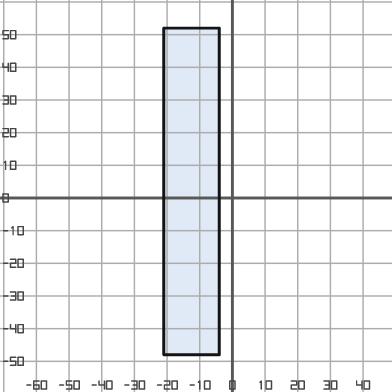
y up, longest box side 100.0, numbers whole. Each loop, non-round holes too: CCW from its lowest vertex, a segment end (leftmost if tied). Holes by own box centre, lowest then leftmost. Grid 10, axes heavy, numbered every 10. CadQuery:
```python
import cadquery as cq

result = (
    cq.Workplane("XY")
    .moveTo(-21.0, -48.0)
    .lineTo(-4.0, -48.0)
    .lineTo(-4.0, 52.0)
    .lineTo(-21.0, 52.0)
    .close()
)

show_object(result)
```